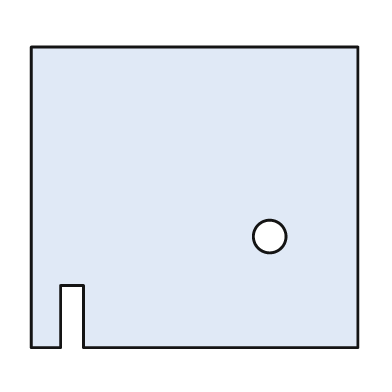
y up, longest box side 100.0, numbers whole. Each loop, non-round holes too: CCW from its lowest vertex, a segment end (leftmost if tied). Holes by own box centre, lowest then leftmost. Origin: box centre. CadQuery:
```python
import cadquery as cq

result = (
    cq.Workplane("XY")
    .moveTo(-50.0, -46.0)
    .lineTo(-41.0, -46.0)
    .lineTo(-41.0, -27.0)
    .lineTo(-34.0, -27.0)
    .lineTo(-34.0, -46.0)
    .lineTo(50.0, -46.0)
    .lineTo(50.0, 46.0)
    .lineTo(-50.0, 46.0)
    .close()
    .moveTo(23.0, -12.0)
    .circle(5.0)
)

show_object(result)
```